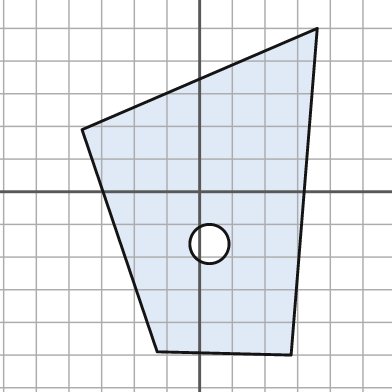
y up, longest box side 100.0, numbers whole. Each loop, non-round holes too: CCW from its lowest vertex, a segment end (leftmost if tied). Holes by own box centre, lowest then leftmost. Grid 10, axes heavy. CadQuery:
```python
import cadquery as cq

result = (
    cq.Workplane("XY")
    .moveTo(28.0, -50.0)
    .lineTo(36.0, 50.0)
    .lineTo(-36.0, 19.0)
    .lineTo(-13.0, -49.0)
    .close()
    .moveTo(3.0, -16.0)
    .circle(6.0)
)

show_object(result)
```